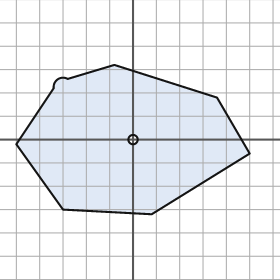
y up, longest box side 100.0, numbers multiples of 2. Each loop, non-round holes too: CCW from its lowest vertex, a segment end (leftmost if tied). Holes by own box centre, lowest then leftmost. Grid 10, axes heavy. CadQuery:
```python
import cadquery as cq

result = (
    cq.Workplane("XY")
    .moveTo(8.0, -32.0)
    .lineTo(50.0, -6.0)
    .lineTo(36.0, 18.0)
    .lineTo(-8.0, 32.0)
    .lineTo(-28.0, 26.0)
    .threePointArc((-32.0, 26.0), (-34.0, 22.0))
    .lineTo(-50.0, -2.0)
    .lineTo(-30.0, -30.0)
    .close()
    .moveTo(0.0, 0.0)
    .circle(2.0)
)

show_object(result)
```